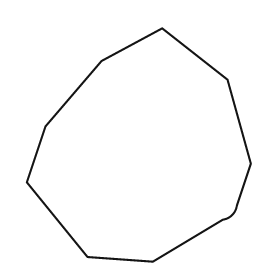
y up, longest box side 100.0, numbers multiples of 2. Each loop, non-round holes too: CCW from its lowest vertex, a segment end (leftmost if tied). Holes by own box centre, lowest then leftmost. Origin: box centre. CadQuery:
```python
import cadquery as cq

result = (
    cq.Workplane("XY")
    .moveTo(6.0, -50.0)
    .lineTo(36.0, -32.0)
    .threePointArc((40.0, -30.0), (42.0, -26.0))
    .lineTo(48.0, -8.0)
    .lineTo(38.0, 28.0)
    .lineTo(10.0, 50.0)
    .lineTo(-16.0, 36.0)
    .lineTo(-40.0, 8.0)
    .lineTo(-48.0, -16.0)
    .lineTo(-22.0, -48.0)
    .close()
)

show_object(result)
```